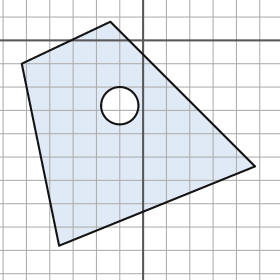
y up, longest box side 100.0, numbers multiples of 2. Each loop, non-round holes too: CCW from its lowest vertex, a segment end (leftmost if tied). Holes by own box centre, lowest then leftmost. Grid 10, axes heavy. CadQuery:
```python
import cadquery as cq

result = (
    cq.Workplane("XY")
    .moveTo(-36.0, -88.0)
    .lineTo(48.0, -54.0)
    .lineTo(-14.0, 8.0)
    .lineTo(-52.0, -10.0)
    .close()
    .moveTo(-10.0, -28.0)
    .circle(8.0)
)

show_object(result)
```